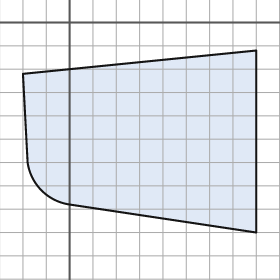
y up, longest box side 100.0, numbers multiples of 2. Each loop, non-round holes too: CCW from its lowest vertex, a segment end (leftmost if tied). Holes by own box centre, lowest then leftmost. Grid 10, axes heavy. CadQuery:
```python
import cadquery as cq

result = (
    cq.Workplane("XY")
    .moveTo(80.0, -90.0)
    .lineTo(80.0, -12.0)
    .lineTo(-20.0, -22.0)
    .lineTo(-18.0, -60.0)
    .threePointArc((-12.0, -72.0), (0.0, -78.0))
    .close()
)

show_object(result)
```